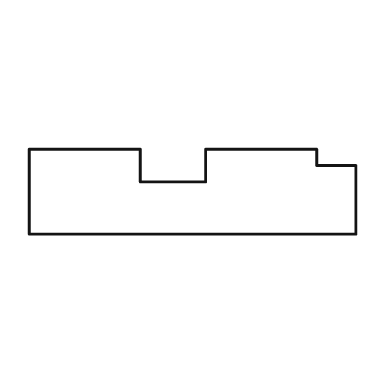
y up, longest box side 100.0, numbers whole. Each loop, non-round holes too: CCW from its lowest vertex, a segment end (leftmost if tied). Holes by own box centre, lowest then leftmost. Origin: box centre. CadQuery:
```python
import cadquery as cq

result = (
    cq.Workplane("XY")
    .moveTo(-50.0, -13.0)
    .lineTo(50.0, -13.0)
    .lineTo(50.0, 8.0)
    .lineTo(38.0, 8.0)
    .lineTo(38.0, 13.0)
    .lineTo(4.0, 13.0)
    .lineTo(4.0, 3.0)
    .lineTo(-16.0, 3.0)
    .lineTo(-16.0, 13.0)
    .lineTo(-50.0, 13.0)
    .close()
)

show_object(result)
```